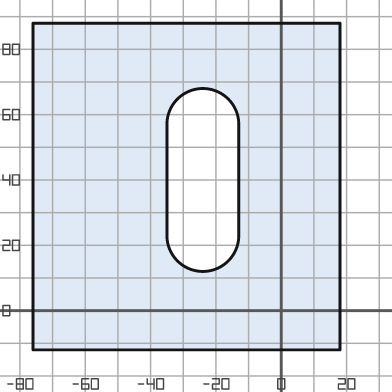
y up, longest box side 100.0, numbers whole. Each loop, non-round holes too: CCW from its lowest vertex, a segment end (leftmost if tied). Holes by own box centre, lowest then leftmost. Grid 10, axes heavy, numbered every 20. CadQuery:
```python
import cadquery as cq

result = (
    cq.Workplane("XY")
    .moveTo(-76.0, -12.0)
    .lineTo(18.0, -12.0)
    .lineTo(18.0, 88.0)
    .lineTo(-76.0, 88.0)
    .close()
    .moveTo(-35.0, 23.0)
    .threePointArc((-24.0, 12.0), (-13.0, 23.0))
    .lineTo(-13.0, 57.0)
    .threePointArc((-24.0, 68.0), (-35.0, 57.0))
    .close()
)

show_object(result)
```